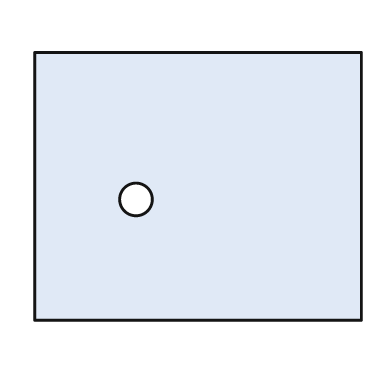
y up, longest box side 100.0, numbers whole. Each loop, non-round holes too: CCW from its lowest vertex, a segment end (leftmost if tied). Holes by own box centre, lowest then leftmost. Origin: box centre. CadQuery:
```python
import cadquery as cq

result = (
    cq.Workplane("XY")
    .moveTo(-50.0, -41.0)
    .lineTo(50.0, -41.0)
    .lineTo(50.0, 41.0)
    .lineTo(-50.0, 41.0)
    .close()
    .moveTo(-19.0, -4.0)
    .circle(5.0)
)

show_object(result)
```